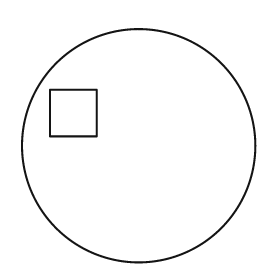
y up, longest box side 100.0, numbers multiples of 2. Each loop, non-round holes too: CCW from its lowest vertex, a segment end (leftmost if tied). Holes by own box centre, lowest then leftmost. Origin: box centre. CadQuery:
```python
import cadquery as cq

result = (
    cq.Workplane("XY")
    .moveTo(0.0, 0.0)
    .circle(50.0)
    .moveTo(-38.0, 4.0)
    .lineTo(-18.0, 4.0)
    .lineTo(-18.0, 24.0)
    .lineTo(-38.0, 24.0)
    .close()
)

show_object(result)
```